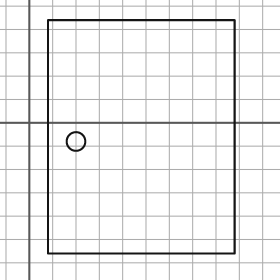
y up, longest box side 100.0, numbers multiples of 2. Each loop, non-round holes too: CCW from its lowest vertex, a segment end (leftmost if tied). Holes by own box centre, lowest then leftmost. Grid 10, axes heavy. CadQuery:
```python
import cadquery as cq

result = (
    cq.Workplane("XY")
    .moveTo(8.0, -56.0)
    .lineTo(88.0, -56.0)
    .lineTo(88.0, 44.0)
    .lineTo(8.0, 44.0)
    .close()
    .moveTo(20.0, -8.0)
    .circle(4.0)
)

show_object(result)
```